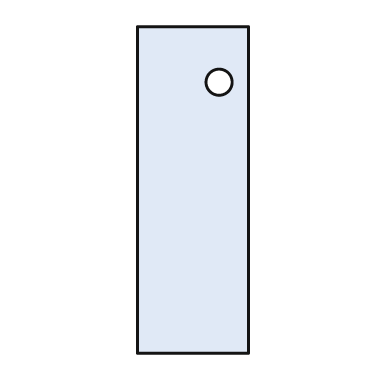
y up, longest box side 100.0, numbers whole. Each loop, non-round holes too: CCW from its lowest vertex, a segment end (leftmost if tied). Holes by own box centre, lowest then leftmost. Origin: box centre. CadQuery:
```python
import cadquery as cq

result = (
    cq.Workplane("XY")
    .moveTo(-17.0, -50.0)
    .lineTo(17.0, -50.0)
    .lineTo(17.0, 50.0)
    .lineTo(-17.0, 50.0)
    .close()
    .moveTo(8.0, 33.0)
    .circle(4.0)
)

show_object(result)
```